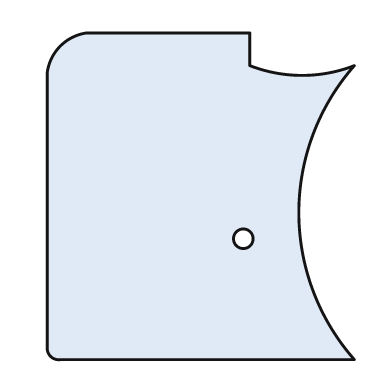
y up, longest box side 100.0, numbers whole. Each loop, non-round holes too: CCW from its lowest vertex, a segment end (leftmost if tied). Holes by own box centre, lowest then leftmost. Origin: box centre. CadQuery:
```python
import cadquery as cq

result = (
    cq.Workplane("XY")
    .moveTo(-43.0, -50.0)
    .lineTo(47.0, -50.0)
    .threePointArc((30.0, -5.0), (47.0, 40.0))
    .threePointArc((31.0, 37.0), (15.0, 40.0))
    .lineTo(15.0, 50.0)
    .lineTo(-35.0, 50.0)
    .threePointArc((-43.0, 46.0), (-47.0, 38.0))
    .lineTo(-47.0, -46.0)
    .threePointArc((-46.0, -49.0), (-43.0, -50.0))
    .close()
    .moveTo(13.0, -13.0)
    .circle(3.0)
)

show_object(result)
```